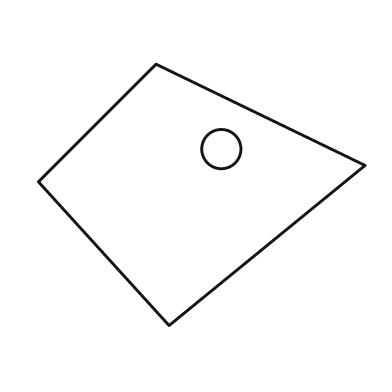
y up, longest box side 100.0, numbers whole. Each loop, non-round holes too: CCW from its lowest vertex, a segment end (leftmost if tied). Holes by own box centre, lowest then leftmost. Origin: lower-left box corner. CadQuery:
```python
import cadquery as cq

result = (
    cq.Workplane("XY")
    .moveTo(40.0, 0.0)
    .lineTo(100.0, 49.0)
    .lineTo(36.0, 80.0)
    .lineTo(0.0, 44.0)
    .close()
    .moveTo(56.0, 54.0)
    .circle(6.0)
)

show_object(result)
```